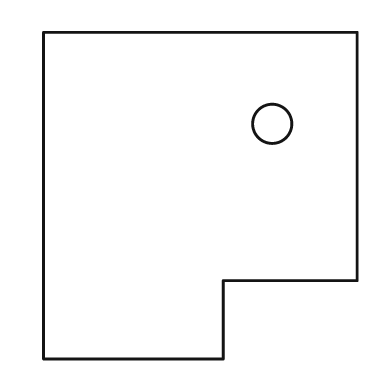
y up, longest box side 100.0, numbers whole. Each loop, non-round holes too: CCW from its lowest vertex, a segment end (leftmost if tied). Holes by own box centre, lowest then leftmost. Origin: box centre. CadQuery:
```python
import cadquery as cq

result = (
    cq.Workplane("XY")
    .moveTo(-48.0, -50.0)
    .lineTo(7.0, -50.0)
    .lineTo(7.0, -26.0)
    .lineTo(48.0, -26.0)
    .lineTo(48.0, 50.0)
    .lineTo(-48.0, 50.0)
    .close()
    .moveTo(22.0, 22.0)
    .circle(6.0)
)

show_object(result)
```